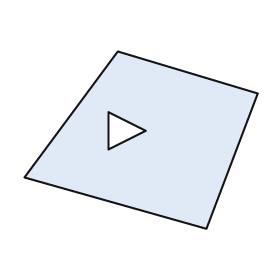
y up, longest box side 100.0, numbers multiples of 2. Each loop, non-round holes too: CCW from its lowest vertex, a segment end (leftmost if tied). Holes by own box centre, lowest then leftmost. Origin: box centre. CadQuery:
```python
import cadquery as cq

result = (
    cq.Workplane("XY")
    .moveTo(28.0, -38.0)
    .lineTo(50.0, 20.0)
    .lineTo(-10.0, 38.0)
    .lineTo(-50.0, -16.0)
    .close()
    .moveTo(-14.0, -4.0)
    .lineTo(2.0, 4.0)
    .lineTo(-14.0, 12.0)
    .close()
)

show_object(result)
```